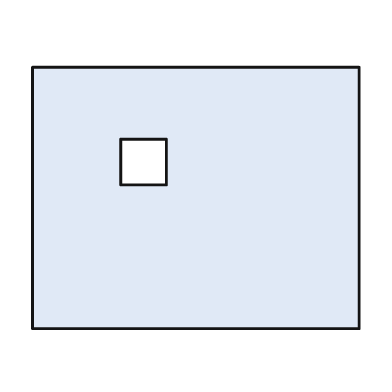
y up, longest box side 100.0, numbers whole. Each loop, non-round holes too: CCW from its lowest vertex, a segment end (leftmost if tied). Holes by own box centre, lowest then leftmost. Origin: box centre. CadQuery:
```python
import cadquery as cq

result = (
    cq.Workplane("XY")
    .moveTo(-50.0, -40.0)
    .lineTo(50.0, -40.0)
    .lineTo(50.0, 40.0)
    .lineTo(-50.0, 40.0)
    .close()
    .moveTo(-23.0, 4.0)
    .lineTo(-9.0, 4.0)
    .lineTo(-9.0, 18.0)
    .lineTo(-23.0, 18.0)
    .close()
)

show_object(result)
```